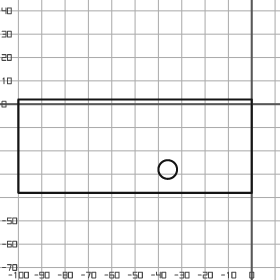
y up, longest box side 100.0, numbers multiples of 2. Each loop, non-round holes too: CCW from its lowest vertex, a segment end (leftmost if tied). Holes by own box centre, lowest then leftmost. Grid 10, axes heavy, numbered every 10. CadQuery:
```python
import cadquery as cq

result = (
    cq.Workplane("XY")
    .moveTo(-100.0, -38.0)
    .lineTo(0.0, -38.0)
    .lineTo(0.0, 2.0)
    .lineTo(-100.0, 2.0)
    .close()
    .moveTo(-36.0, -28.0)
    .circle(4.0)
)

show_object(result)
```